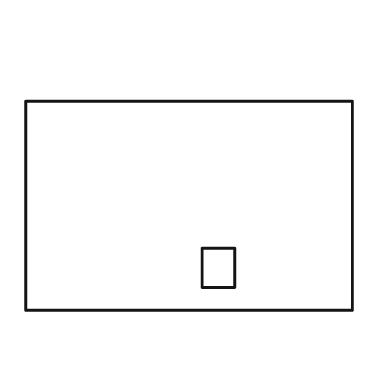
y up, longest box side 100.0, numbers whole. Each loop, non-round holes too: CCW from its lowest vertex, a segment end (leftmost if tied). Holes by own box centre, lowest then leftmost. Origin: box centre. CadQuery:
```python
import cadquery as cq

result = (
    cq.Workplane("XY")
    .moveTo(-50.0, -32.0)
    .lineTo(50.0, -32.0)
    .lineTo(50.0, 32.0)
    .lineTo(-50.0, 32.0)
    .close()
    .moveTo(4.0, -25.0)
    .lineTo(14.0, -25.0)
    .lineTo(14.0, -13.0)
    .lineTo(4.0, -13.0)
    .close()
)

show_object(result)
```